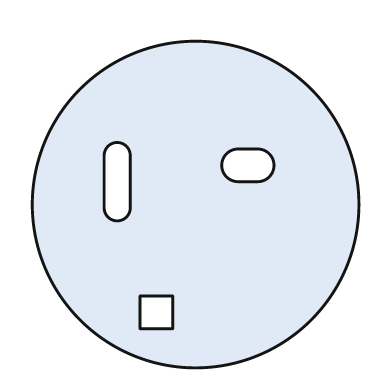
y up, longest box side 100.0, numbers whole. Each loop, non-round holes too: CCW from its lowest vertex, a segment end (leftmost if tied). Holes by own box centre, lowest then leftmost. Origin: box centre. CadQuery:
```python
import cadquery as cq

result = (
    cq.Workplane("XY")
    .moveTo(0.0, 0.0)
    .circle(50.0)
    .moveTo(-17.0, -38.0)
    .lineTo(-7.0, -38.0)
    .lineTo(-7.0, -28.0)
    .lineTo(-17.0, -28.0)
    .close()
    .moveTo(-28.0, -1.0)
    .threePointArc((-24.0, -5.0), (-20.0, -1.0))
    .lineTo(-20.0, 15.0)
    .threePointArc((-24.0, 19.0), (-28.0, 15.0))
    .close()
    .moveTo(13.0, 7.0)
    .lineTo(19.0, 7.0)
    .threePointArc((24.0, 12.0), (19.0, 17.0))
    .lineTo(13.0, 17.0)
    .threePointArc((8.0, 12.0), (13.0, 7.0))
    .close()
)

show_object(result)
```